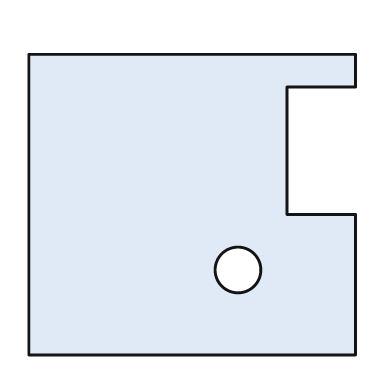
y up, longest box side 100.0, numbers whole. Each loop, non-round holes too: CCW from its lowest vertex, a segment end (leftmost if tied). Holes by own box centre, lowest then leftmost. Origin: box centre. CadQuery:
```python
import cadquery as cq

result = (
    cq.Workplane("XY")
    .moveTo(-50.0, -46.0)
    .lineTo(50.0, -46.0)
    .lineTo(50.0, -3.0)
    .lineTo(29.0, -3.0)
    .lineTo(29.0, 36.0)
    .lineTo(50.0, 36.0)
    .lineTo(50.0, 46.0)
    .lineTo(-50.0, 46.0)
    .close()
    .moveTo(14.0, -20.0)
    .circle(7.0)
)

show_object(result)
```